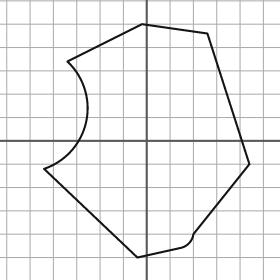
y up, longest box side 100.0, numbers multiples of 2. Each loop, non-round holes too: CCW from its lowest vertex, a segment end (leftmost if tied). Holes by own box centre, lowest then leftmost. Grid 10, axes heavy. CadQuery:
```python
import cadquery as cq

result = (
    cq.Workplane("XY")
    .moveTo(-4.0, -50.0)
    .lineTo(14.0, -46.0)
    .threePointArc((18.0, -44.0), (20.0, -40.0))
    .lineTo(44.0, -10.0)
    .lineTo(26.0, 46.0)
    .lineTo(-2.0, 50.0)
    .lineTo(-34.0, 34.0)
    .threePointArc((-26.0, 8.0), (-44.0, -12.0))
    .close()
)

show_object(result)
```